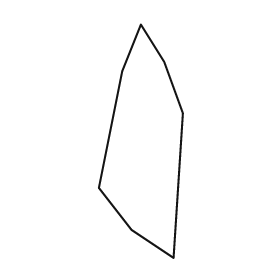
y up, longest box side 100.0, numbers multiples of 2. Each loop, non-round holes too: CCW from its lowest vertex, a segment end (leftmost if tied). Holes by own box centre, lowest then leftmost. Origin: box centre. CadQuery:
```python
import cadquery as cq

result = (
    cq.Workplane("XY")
    .moveTo(14.0, -50.0)
    .lineTo(18.0, 12.0)
    .lineTo(10.0, 34.0)
    .lineTo(0.0, 50.0)
    .lineTo(-8.0, 30.0)
    .lineTo(-18.0, -20.0)
    .lineTo(-4.0, -38.0)
    .close()
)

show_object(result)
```